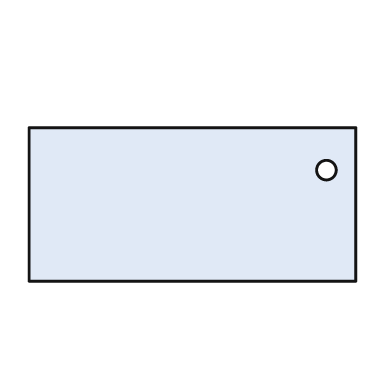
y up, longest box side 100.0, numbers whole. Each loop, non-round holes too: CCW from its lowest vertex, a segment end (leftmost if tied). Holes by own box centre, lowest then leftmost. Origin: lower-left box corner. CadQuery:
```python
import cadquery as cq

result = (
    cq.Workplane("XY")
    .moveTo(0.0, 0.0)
    .lineTo(100.0, 0.0)
    .lineTo(100.0, 47.0)
    .lineTo(0.0, 47.0)
    .close()
    .moveTo(91.0, 34.0)
    .circle(3.0)
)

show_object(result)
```